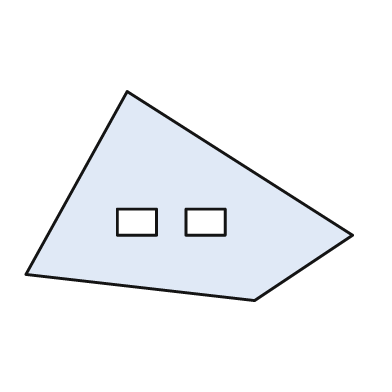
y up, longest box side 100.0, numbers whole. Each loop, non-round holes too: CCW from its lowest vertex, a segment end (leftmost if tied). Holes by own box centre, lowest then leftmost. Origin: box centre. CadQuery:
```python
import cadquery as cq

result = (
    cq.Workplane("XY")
    .moveTo(20.0, -32.0)
    .lineTo(50.0, -12.0)
    .lineTo(-19.0, 32.0)
    .lineTo(-50.0, -24.0)
    .close()
    .moveTo(-22.0, -12.0)
    .lineTo(-10.0, -12.0)
    .lineTo(-10.0, -4.0)
    .lineTo(-22.0, -4.0)
    .close()
    .moveTo(-1.0, -12.0)
    .lineTo(11.0, -12.0)
    .lineTo(11.0, -4.0)
    .lineTo(-1.0, -4.0)
    .close()
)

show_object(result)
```